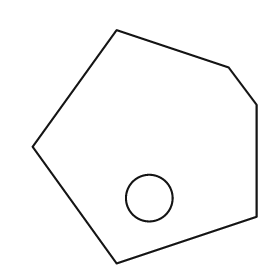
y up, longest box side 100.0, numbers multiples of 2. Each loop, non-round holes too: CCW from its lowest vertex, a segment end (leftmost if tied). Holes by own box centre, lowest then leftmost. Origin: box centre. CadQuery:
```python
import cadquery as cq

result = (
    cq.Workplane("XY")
    .moveTo(-12.0, -50.0)
    .lineTo(48.0, -30.0)
    .lineTo(48.0, 18.0)
    .lineTo(36.0, 34.0)
    .lineTo(-12.0, 50.0)
    .lineTo(-48.0, 0.0)
    .close()
    .moveTo(2.0, -22.0)
    .circle(10.0)
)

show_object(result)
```